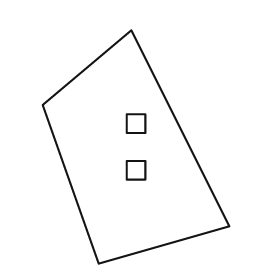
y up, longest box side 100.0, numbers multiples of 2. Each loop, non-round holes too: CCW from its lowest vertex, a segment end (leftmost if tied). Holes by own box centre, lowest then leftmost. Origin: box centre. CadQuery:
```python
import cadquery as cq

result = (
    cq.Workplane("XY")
    .moveTo(-16.0, -50.0)
    .lineTo(40.0, -34.0)
    .lineTo(-2.0, 50.0)
    .lineTo(-40.0, 18.0)
    .close()
    .moveTo(-4.0, -14.0)
    .lineTo(4.0, -14.0)
    .lineTo(4.0, -6.0)
    .lineTo(-4.0, -6.0)
    .close()
    .moveTo(-4.0, 6.0)
    .lineTo(4.0, 6.0)
    .lineTo(4.0, 14.0)
    .lineTo(-4.0, 14.0)
    .close()
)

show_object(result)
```